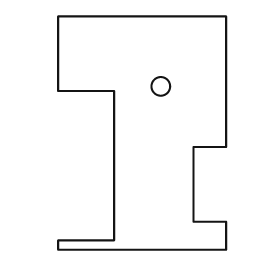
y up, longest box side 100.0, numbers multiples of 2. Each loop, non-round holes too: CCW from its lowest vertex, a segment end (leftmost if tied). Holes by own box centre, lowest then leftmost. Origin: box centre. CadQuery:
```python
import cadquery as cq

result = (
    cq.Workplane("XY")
    .moveTo(-36.0, -50.0)
    .lineTo(36.0, -50.0)
    .lineTo(36.0, -38.0)
    .lineTo(22.0, -38.0)
    .lineTo(22.0, -6.0)
    .lineTo(36.0, -6.0)
    .lineTo(36.0, 50.0)
    .lineTo(-36.0, 50.0)
    .lineTo(-36.0, 18.0)
    .lineTo(-12.0, 18.0)
    .lineTo(-12.0, -46.0)
    .lineTo(-36.0, -46.0)
    .close()
    .moveTo(8.0, 20.0)
    .circle(4.0)
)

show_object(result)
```